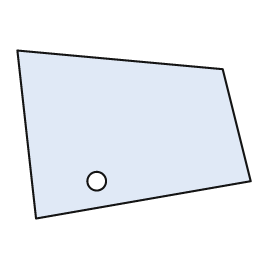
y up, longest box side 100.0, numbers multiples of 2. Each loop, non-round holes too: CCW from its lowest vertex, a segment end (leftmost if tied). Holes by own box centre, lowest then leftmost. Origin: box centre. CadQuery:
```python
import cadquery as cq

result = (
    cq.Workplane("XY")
    .moveTo(-42.0, -36.0)
    .lineTo(50.0, -20.0)
    .lineTo(38.0, 28.0)
    .lineTo(-50.0, 36.0)
    .close()
    .moveTo(-16.0, -20.0)
    .circle(4.0)
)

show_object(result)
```